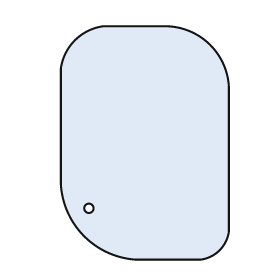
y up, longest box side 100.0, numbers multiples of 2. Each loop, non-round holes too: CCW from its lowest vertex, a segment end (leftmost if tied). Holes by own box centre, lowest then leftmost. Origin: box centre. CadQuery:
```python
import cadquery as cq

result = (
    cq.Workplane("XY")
    .moveTo(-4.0, -50.0)
    .lineTo(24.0, -50.0)
    .threePointArc((32.0, -46.0), (36.0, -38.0))
    .lineTo(36.0, 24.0)
    .threePointArc((28.0, 42.0), (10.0, 50.0))
    .lineTo(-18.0, 50.0)
    .threePointArc((-30.0, 44.0), (-36.0, 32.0))
    .lineTo(-36.0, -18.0)
    .threePointArc((-26.0, -40.0), (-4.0, -50.0))
    .close()
    .moveTo(-24.0, -28.0)
    .circle(2.0)
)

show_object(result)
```